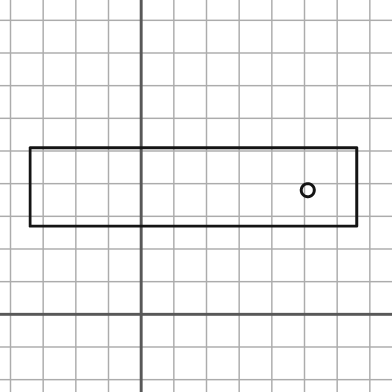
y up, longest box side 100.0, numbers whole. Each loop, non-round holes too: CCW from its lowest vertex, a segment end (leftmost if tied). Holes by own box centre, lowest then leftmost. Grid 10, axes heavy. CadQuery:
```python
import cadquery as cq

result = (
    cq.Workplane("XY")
    .moveTo(-34.0, 27.0)
    .lineTo(66.0, 27.0)
    .lineTo(66.0, 51.0)
    .lineTo(-34.0, 51.0)
    .close()
    .moveTo(51.0, 38.0)
    .circle(2.0)
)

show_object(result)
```